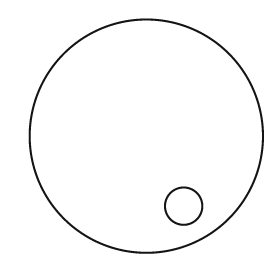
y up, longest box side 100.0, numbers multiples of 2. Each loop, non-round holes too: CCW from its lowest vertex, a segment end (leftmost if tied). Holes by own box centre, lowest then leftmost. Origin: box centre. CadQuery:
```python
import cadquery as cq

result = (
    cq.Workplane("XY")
    .moveTo(0.0, 0.0)
    .circle(50.0)
    .moveTo(16.0, -30.0)
    .circle(8.0)
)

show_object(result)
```